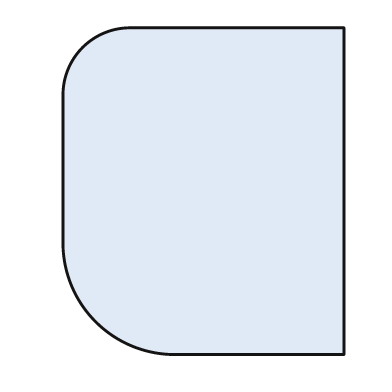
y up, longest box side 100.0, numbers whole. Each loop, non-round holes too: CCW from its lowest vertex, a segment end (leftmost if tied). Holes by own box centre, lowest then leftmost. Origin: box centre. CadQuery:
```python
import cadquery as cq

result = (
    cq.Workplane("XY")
    .moveTo(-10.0, -50.0)
    .lineTo(43.0, -50.0)
    .lineTo(43.0, 50.0)
    .lineTo(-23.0, 50.0)
    .threePointArc((-37.0, 44.0), (-43.0, 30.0))
    .lineTo(-43.0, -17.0)
    .threePointArc((-33.0, -40.0), (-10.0, -50.0))
    .close()
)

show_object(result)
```